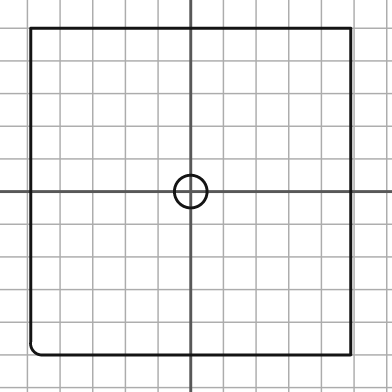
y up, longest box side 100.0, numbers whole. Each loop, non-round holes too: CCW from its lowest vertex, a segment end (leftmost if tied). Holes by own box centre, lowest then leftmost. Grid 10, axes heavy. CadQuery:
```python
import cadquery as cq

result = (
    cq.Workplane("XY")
    .moveTo(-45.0, -50.0)
    .lineTo(49.0, -50.0)
    .lineTo(49.0, 50.0)
    .lineTo(-49.0, 50.0)
    .lineTo(-49.0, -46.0)
    .threePointArc((-48.0, -49.0), (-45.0, -50.0))
    .close()
    .moveTo(0.0, 0.0)
    .circle(5.0)
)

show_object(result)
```